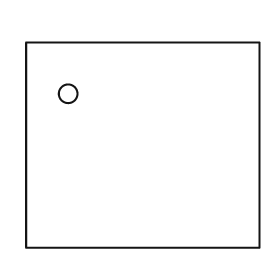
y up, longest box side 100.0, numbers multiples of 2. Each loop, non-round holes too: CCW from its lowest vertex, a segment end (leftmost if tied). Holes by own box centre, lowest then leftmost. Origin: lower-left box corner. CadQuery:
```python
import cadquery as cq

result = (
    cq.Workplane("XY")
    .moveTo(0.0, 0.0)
    .lineTo(100.0, 0.0)
    .lineTo(100.0, 88.0)
    .lineTo(0.0, 88.0)
    .close()
    .moveTo(18.0, 66.0)
    .circle(4.0)
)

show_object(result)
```